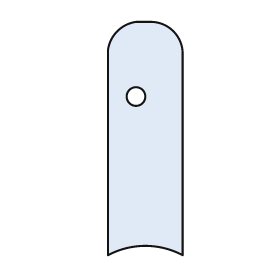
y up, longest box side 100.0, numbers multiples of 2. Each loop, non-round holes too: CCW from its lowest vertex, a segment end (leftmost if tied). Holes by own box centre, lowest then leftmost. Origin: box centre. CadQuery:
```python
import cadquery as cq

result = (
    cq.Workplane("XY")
    .moveTo(-16.0, -50.0)
    .threePointArc((0.0, -46.0), (16.0, -50.0))
    .lineTo(16.0, 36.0)
    .threePointArc((12.0, 46.0), (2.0, 50.0))
    .lineTo(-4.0, 50.0)
    .threePointArc((-12.0, 46.0), (-16.0, 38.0))
    .close()
    .moveTo(-4.0, 18.0)
    .circle(4.0)
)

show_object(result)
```